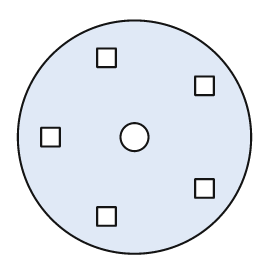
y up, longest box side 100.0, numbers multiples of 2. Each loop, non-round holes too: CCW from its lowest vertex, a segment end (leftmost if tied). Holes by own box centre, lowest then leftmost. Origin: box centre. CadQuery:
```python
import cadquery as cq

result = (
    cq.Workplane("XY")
    .moveTo(0.0, 0.0)
    .circle(50.0)
    .moveTo(-16.0, -38.0)
    .lineTo(-8.0, -38.0)
    .lineTo(-8.0, -30.0)
    .lineTo(-16.0, -30.0)
    .close()
    .moveTo(26.0, -26.0)
    .lineTo(34.0, -26.0)
    .lineTo(34.0, -18.0)
    .lineTo(26.0, -18.0)
    .close()
    .moveTo(-40.0, -4.0)
    .lineTo(-32.0, -4.0)
    .lineTo(-32.0, 4.0)
    .lineTo(-40.0, 4.0)
    .close()
    .moveTo(0.0, 0.0)
    .circle(6.0)
    .moveTo(26.0, 18.0)
    .lineTo(34.0, 18.0)
    .lineTo(34.0, 26.0)
    .lineTo(26.0, 26.0)
    .close()
    .moveTo(-16.0, 30.0)
    .lineTo(-8.0, 30.0)
    .lineTo(-8.0, 38.0)
    .lineTo(-16.0, 38.0)
    .close()
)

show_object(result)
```